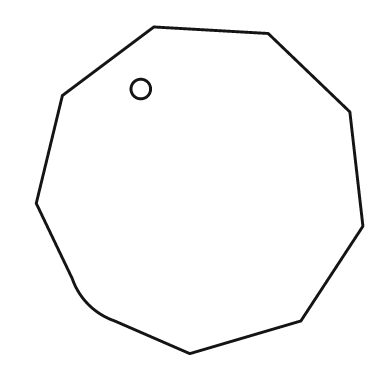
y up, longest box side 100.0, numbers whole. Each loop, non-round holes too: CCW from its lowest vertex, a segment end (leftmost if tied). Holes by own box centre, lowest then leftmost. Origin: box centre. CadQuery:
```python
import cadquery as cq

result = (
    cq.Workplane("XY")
    .moveTo(-3.0, -50.0)
    .lineTo(31.0, -40.0)
    .lineTo(50.0, -11.0)
    .lineTo(46.0, 24.0)
    .lineTo(21.0, 48.0)
    .lineTo(-14.0, 50.0)
    .lineTo(-42.0, 29.0)
    .lineTo(-50.0, -4.0)
    .lineTo(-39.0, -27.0)
    .threePointArc((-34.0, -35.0), (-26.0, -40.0))
    .close()
    .moveTo(-18.0, 31.0)
    .circle(3.0)
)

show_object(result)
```